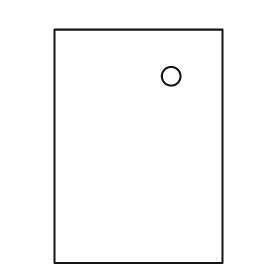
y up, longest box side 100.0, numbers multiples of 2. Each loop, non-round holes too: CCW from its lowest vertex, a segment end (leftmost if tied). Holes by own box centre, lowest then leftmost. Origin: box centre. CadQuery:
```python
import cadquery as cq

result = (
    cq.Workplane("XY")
    .moveTo(-36.0, -50.0)
    .lineTo(36.0, -50.0)
    .lineTo(36.0, 50.0)
    .lineTo(-36.0, 50.0)
    .close()
    .moveTo(14.0, 30.0)
    .circle(4.0)
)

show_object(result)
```